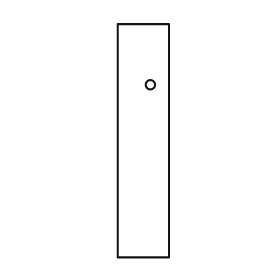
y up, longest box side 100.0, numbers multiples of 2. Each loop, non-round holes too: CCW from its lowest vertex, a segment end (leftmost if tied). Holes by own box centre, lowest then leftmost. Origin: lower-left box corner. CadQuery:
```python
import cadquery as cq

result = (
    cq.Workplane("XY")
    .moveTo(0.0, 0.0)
    .lineTo(22.0, 0.0)
    .lineTo(22.0, 100.0)
    .lineTo(0.0, 100.0)
    .close()
    .moveTo(14.0, 74.0)
    .circle(2.0)
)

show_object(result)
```